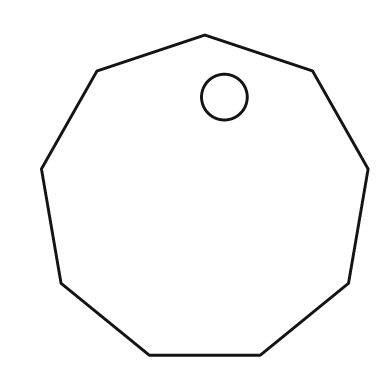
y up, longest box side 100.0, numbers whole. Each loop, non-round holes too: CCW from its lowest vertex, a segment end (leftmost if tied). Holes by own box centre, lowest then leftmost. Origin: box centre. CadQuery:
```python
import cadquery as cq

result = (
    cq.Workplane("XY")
    .moveTo(-17.0, -49.0)
    .lineTo(17.0, -49.0)
    .lineTo(44.0, -27.0)
    .lineTo(50.0, 8.0)
    .lineTo(33.0, 38.0)
    .lineTo(0.0, 49.0)
    .lineTo(-33.0, 38.0)
    .lineTo(-50.0, 8.0)
    .lineTo(-44.0, -27.0)
    .close()
    .moveTo(6.0, 30.0)
    .circle(7.0)
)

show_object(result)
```